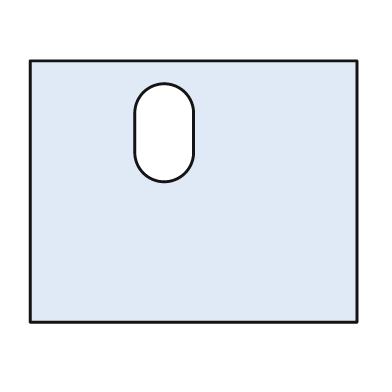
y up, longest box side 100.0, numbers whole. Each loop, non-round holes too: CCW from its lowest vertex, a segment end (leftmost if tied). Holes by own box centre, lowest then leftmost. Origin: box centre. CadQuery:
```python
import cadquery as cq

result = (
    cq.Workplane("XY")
    .moveTo(-50.0, -40.0)
    .lineTo(50.0, -40.0)
    .lineTo(50.0, 40.0)
    .lineTo(-50.0, 40.0)
    .close()
    .moveTo(-18.0, 12.0)
    .threePointArc((-9.0, 3.0), (0.0, 12.0))
    .lineTo(0.0, 24.0)
    .threePointArc((-9.0, 33.0), (-18.0, 24.0))
    .close()
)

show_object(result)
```